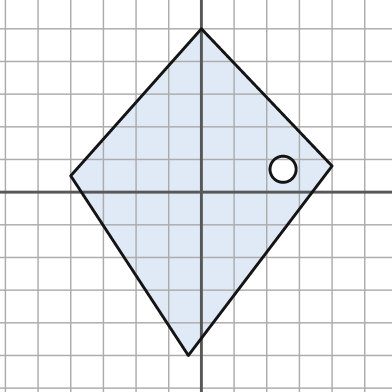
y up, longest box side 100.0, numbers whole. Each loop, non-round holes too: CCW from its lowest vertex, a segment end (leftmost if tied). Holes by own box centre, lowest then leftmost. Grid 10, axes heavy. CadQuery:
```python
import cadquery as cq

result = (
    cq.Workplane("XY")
    .moveTo(-4.0, -50.0)
    .lineTo(40.0, 8.0)
    .lineTo(0.0, 50.0)
    .lineTo(-40.0, 5.0)
    .close()
    .moveTo(25.0, 7.0)
    .circle(4.0)
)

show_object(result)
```